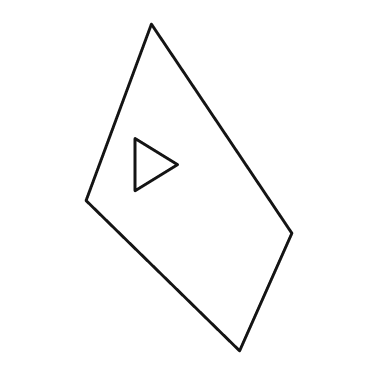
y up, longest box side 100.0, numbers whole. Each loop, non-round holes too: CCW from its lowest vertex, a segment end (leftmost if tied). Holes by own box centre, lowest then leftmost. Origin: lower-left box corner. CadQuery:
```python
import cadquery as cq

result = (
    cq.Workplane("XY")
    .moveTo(47.0, 0.0)
    .lineTo(63.0, 36.0)
    .lineTo(20.0, 100.0)
    .lineTo(0.0, 46.0)
    .close()
    .moveTo(15.0, 49.0)
    .lineTo(28.0, 57.0)
    .lineTo(15.0, 65.0)
    .close()
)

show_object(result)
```